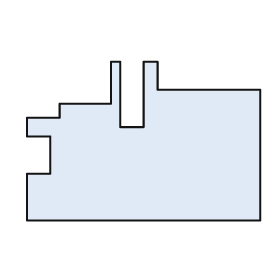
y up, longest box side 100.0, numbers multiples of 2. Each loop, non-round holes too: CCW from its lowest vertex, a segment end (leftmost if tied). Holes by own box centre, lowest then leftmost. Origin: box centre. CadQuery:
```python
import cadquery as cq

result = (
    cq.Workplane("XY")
    .moveTo(-50.0, -34.0)
    .lineTo(50.0, -34.0)
    .lineTo(50.0, 22.0)
    .lineTo(6.0, 22.0)
    .lineTo(6.0, 34.0)
    .lineTo(0.0, 34.0)
    .lineTo(0.0, 6.0)
    .lineTo(-10.0, 6.0)
    .lineTo(-10.0, 34.0)
    .lineTo(-14.0, 34.0)
    .lineTo(-14.0, 16.0)
    .lineTo(-36.0, 16.0)
    .lineTo(-36.0, 10.0)
    .lineTo(-50.0, 10.0)
    .lineTo(-50.0, 2.0)
    .lineTo(-40.0, 2.0)
    .lineTo(-40.0, -14.0)
    .lineTo(-50.0, -14.0)
    .close()
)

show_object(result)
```